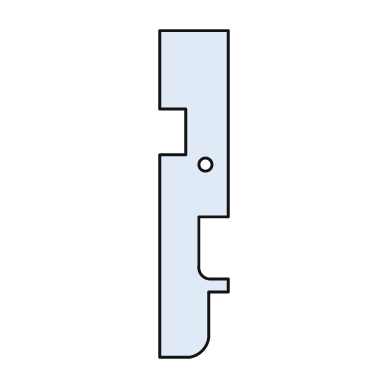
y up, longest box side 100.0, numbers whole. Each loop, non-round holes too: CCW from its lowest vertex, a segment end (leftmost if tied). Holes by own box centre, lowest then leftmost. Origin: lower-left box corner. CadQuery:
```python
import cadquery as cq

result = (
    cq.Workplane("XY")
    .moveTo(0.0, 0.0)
    .lineTo(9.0, 0.0)
    .threePointArc((13.0, 2.0), (15.0, 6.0))
    .lineTo(15.0, 20.0)
    .lineTo(21.0, 20.0)
    .lineTo(21.0, 24.0)
    .lineTo(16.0, 24.0)
    .threePointArc((13.0, 25.0), (12.0, 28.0))
    .lineTo(12.0, 43.0)
    .lineTo(21.0, 43.0)
    .lineTo(21.0, 100.0)
    .lineTo(0.0, 100.0)
    .lineTo(0.0, 76.0)
    .lineTo(8.0, 76.0)
    .lineTo(8.0, 62.0)
    .lineTo(0.0, 62.0)
    .close()
    .moveTo(14.0, 59.0)
    .circle(2.0)
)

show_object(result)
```